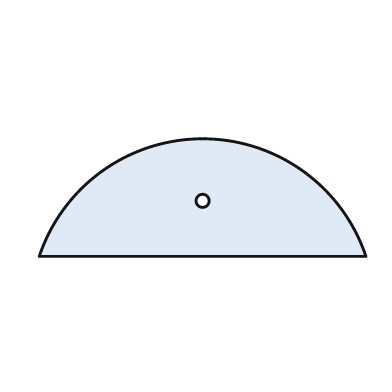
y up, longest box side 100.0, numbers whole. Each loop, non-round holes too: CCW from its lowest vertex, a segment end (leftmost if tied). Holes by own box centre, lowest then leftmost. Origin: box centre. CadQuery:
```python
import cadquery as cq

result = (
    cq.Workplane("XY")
    .moveTo(-50.0, -18.0)
    .lineTo(50.0, -18.0)
    .threePointArc((0.0, 18.0), (-50.0, -18.0))
    .close()
    .moveTo(0.0, -1.0)
    .circle(2.0)
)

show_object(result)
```